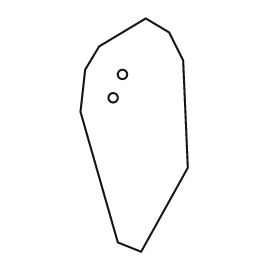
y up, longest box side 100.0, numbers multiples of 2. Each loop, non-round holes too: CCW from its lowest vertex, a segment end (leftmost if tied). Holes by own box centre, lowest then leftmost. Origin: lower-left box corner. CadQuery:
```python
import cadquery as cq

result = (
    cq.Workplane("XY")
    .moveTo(26.0, 0.0)
    .lineTo(46.0, 36.0)
    .lineTo(44.0, 82.0)
    .lineTo(38.0, 94.0)
    .lineTo(28.0, 100.0)
    .lineTo(8.0, 88.0)
    .lineTo(2.0, 78.0)
    .lineTo(0.0, 60.0)
    .lineTo(16.0, 4.0)
    .close()
    .moveTo(14.0, 66.0)
    .circle(2.0)
    .moveTo(18.0, 76.0)
    .circle(2.0)
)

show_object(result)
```